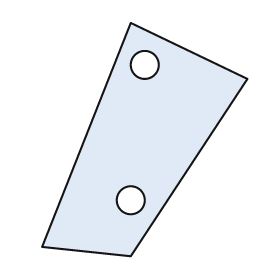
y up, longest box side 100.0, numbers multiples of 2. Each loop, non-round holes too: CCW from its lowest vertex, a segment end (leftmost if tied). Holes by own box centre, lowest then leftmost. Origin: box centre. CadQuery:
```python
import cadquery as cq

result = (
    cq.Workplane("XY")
    .moveTo(-6.0, -50.0)
    .lineTo(44.0, 26.0)
    .lineTo(-6.0, 50.0)
    .lineTo(-44.0, -46.0)
    .close()
    .moveTo(-6.0, -26.0)
    .circle(6.0)
    .moveTo(0.0, 32.0)
    .circle(6.0)
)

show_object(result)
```